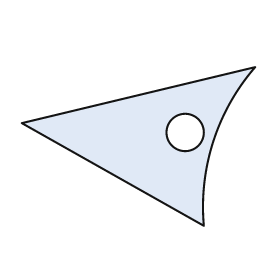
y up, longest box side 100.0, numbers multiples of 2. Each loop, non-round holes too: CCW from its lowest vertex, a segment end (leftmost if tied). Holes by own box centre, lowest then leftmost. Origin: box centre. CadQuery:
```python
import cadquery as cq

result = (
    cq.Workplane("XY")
    .moveTo(28.0, -34.0)
    .threePointArc((32.0, 2.0), (50.0, 34.0))
    .lineTo(-50.0, 10.0)
    .close()
    .moveTo(20.0, 6.0)
    .circle(8.0)
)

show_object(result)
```